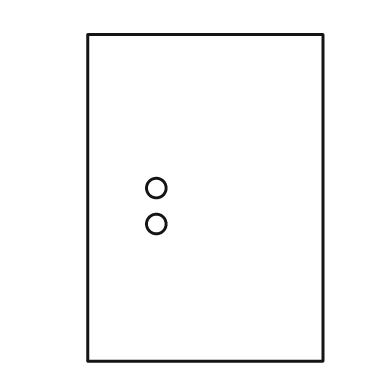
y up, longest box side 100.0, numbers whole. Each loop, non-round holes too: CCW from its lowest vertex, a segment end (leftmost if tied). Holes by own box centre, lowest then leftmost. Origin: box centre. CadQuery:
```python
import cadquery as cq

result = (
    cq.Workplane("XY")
    .moveTo(-36.0, -50.0)
    .lineTo(36.0, -50.0)
    .lineTo(36.0, 50.0)
    .lineTo(-36.0, 50.0)
    .close()
    .moveTo(-15.0, -8.0)
    .circle(3.0)
    .moveTo(-15.0, 3.0)
    .circle(3.0)
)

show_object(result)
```